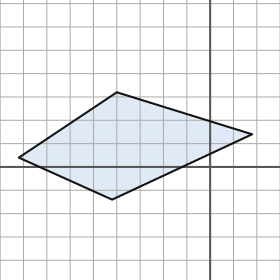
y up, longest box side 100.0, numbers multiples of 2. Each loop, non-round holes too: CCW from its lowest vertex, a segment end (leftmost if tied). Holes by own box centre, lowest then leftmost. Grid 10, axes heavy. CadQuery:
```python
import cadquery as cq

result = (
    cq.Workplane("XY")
    .moveTo(-42.0, -14.0)
    .lineTo(18.0, 14.0)
    .lineTo(-40.0, 32.0)
    .lineTo(-82.0, 4.0)
    .close()
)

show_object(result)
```